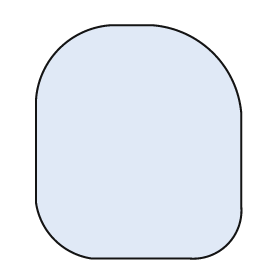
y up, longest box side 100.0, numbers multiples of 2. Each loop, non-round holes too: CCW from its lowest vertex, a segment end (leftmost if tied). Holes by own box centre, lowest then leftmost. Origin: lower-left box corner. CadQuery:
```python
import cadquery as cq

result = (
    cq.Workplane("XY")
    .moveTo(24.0, 0.0)
    .lineTo(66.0, 0.0)
    .threePointArc((82.0, 6.0), (88.0, 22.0))
    .lineTo(88.0, 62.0)
    .threePointArc((76.0, 88.0), (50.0, 100.0))
    .lineTo(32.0, 100.0)
    .threePointArc((10.0, 90.0), (0.0, 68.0))
    .lineTo(0.0, 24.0)
    .threePointArc((8.0, 8.0), (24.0, 0.0))
    .close()
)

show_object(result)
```